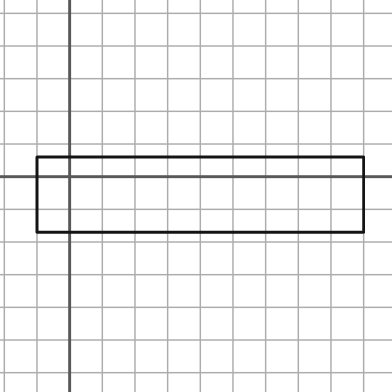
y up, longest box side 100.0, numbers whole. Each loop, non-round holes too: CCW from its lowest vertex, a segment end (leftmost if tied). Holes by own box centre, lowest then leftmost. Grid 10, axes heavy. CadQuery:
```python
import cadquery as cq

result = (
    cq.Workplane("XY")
    .moveTo(-10.0, -17.0)
    .lineTo(90.0, -17.0)
    .lineTo(90.0, 6.0)
    .lineTo(-10.0, 6.0)
    .close()
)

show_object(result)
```